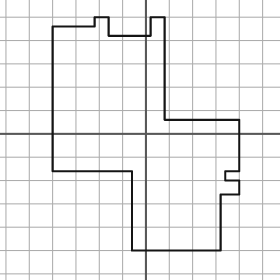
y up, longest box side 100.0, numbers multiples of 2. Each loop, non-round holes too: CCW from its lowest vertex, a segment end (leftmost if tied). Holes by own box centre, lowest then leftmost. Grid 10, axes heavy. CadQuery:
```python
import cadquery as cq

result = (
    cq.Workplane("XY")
    .moveTo(-6.0, -50.0)
    .lineTo(32.0, -50.0)
    .lineTo(32.0, -26.0)
    .lineTo(40.0, -26.0)
    .lineTo(40.0, -20.0)
    .lineTo(34.0, -20.0)
    .lineTo(34.0, -16.0)
    .lineTo(40.0, -16.0)
    .lineTo(40.0, 6.0)
    .lineTo(8.0, 6.0)
    .lineTo(8.0, 50.0)
    .lineTo(2.0, 50.0)
    .lineTo(2.0, 42.0)
    .lineTo(-16.0, 42.0)
    .lineTo(-16.0, 50.0)
    .lineTo(-22.0, 50.0)
    .lineTo(-22.0, 46.0)
    .lineTo(-40.0, 46.0)
    .lineTo(-40.0, -16.0)
    .lineTo(-6.0, -16.0)
    .close()
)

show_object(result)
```